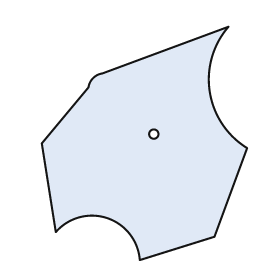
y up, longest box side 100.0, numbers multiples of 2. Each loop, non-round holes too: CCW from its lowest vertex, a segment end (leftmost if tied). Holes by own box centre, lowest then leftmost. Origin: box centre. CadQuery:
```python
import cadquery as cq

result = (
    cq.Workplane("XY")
    .moveTo(-2.0, -50.0)
    .lineTo(30.0, -40.0)
    .lineTo(44.0, -2.0)
    .threePointArc((28.0, 22.0), (36.0, 50.0))
    .lineTo(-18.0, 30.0)
    .threePointArc((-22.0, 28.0), (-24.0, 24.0))
    .lineTo(-44.0, 0.0)
    .lineTo(-38.0, -38.0)
    .threePointArc((-16.0, -32.0), (-2.0, -50.0))
    .close()
    .moveTo(4.0, 4.0)
    .circle(2.0)
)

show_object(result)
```